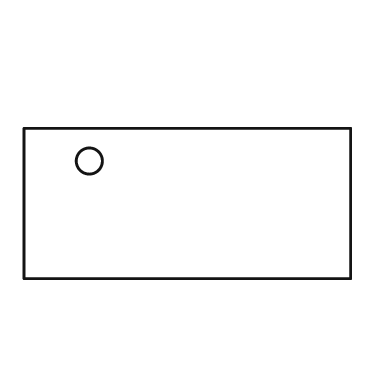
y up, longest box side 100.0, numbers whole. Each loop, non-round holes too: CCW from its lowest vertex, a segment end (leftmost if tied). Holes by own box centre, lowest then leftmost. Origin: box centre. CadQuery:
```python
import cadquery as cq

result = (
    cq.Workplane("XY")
    .moveTo(-50.0, -23.0)
    .lineTo(50.0, -23.0)
    .lineTo(50.0, 23.0)
    .lineTo(-50.0, 23.0)
    .close()
    .moveTo(-30.0, 13.0)
    .circle(4.0)
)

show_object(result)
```